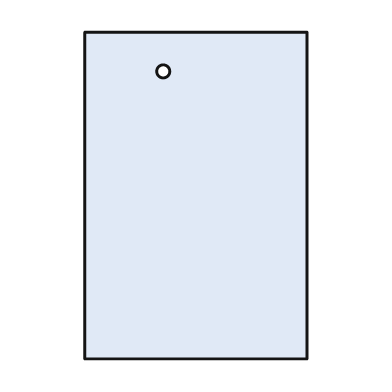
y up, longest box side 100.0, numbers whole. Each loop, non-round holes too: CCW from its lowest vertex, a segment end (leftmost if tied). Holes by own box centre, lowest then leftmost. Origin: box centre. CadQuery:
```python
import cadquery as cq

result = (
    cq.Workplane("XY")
    .moveTo(-34.0, -50.0)
    .lineTo(34.0, -50.0)
    .lineTo(34.0, 50.0)
    .lineTo(-34.0, 50.0)
    .close()
    .moveTo(-10.0, 38.0)
    .circle(2.0)
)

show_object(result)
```